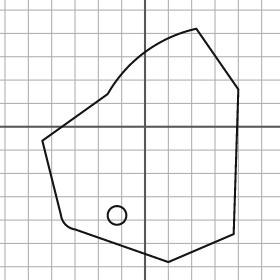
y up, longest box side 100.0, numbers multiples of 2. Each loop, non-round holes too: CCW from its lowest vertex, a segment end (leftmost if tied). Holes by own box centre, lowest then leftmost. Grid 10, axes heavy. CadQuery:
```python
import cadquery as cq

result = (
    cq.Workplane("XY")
    .moveTo(10.0, -58.0)
    .lineTo(38.0, -46.0)
    .lineTo(40.0, 16.0)
    .lineTo(22.0, 42.0)
    .threePointArc((0.0, 32.0), (-16.0, 14.0))
    .lineTo(-44.0, -6.0)
    .lineTo(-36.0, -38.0)
    .threePointArc((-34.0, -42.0), (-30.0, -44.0))
    .close()
    .moveTo(-12.0, -38.0)
    .circle(4.0)
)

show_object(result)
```